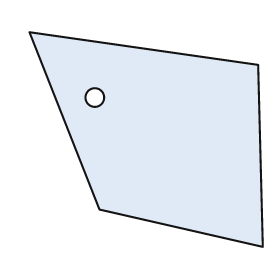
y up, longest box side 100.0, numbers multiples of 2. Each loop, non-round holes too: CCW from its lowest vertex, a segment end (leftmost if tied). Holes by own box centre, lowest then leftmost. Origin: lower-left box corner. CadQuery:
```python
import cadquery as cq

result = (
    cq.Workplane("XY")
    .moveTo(100.0, 0.0)
    .lineTo(98.0, 78.0)
    .lineTo(0.0, 92.0)
    .lineTo(30.0, 16.0)
    .close()
    .moveTo(28.0, 64.0)
    .circle(4.0)
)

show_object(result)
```